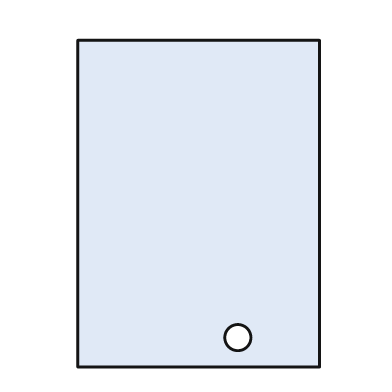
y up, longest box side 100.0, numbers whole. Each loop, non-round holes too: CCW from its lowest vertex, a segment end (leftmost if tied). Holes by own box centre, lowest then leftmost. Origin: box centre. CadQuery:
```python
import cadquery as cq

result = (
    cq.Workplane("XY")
    .moveTo(-37.0, -50.0)
    .lineTo(37.0, -50.0)
    .lineTo(37.0, 50.0)
    .lineTo(-37.0, 50.0)
    .close()
    .moveTo(12.0, -41.0)
    .circle(4.0)
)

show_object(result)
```